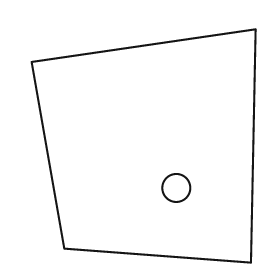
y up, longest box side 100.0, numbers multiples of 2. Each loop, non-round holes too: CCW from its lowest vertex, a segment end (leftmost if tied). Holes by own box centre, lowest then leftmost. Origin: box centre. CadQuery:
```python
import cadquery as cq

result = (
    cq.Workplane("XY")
    .moveTo(46.0, -50.0)
    .lineTo(48.0, 50.0)
    .lineTo(-48.0, 36.0)
    .lineTo(-34.0, -44.0)
    .close()
    .moveTo(14.0, -18.0)
    .circle(6.0)
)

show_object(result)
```